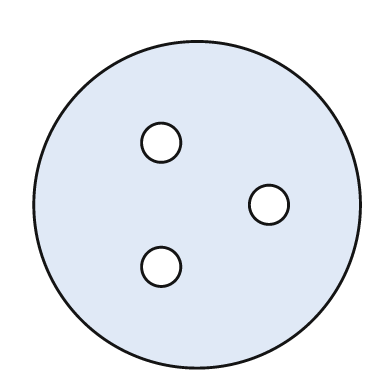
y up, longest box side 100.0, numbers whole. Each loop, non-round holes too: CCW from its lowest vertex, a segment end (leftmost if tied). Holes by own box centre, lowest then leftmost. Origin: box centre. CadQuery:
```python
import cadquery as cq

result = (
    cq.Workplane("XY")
    .moveTo(0.0, 0.0)
    .circle(50.0)
    .moveTo(-11.0, -19.0)
    .circle(6.0)
    .moveTo(22.0, 0.0)
    .circle(6.0)
    .moveTo(-11.0, 19.0)
    .circle(6.0)
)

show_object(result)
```